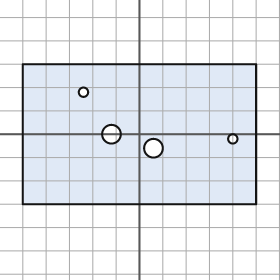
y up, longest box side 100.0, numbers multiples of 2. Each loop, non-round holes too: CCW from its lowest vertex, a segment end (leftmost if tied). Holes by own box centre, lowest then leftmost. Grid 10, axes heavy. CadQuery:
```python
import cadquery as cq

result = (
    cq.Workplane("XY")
    .moveTo(-50.0, -30.0)
    .lineTo(50.0, -30.0)
    .lineTo(50.0, 30.0)
    .lineTo(-50.0, 30.0)
    .close()
    .moveTo(6.0, -6.0)
    .circle(4.0)
    .moveTo(40.0, -2.0)
    .circle(2.0)
    .moveTo(-12.0, 0.0)
    .circle(4.0)
    .moveTo(-24.0, 18.0)
    .circle(2.0)
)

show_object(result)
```